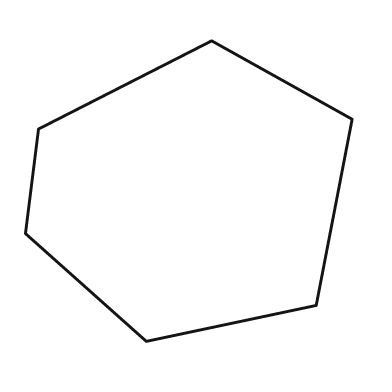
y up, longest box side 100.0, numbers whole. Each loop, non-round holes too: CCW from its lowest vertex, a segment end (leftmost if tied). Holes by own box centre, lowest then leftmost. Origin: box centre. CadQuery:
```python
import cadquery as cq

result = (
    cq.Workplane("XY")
    .moveTo(-13.0, -46.0)
    .lineTo(39.0, -35.0)
    .lineTo(50.0, 22.0)
    .lineTo(7.0, 46.0)
    .lineTo(-46.0, 19.0)
    .lineTo(-50.0, -13.0)
    .close()
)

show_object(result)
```